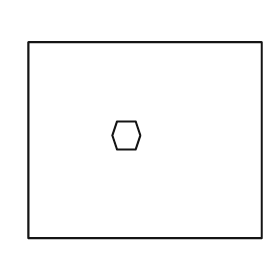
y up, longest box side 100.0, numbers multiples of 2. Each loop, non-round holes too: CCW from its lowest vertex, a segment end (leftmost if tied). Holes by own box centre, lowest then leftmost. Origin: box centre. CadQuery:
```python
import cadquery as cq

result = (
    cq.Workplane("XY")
    .moveTo(-50.0, -42.0)
    .lineTo(50.0, -42.0)
    .lineTo(50.0, 42.0)
    .lineTo(-50.0, 42.0)
    .close()
    .moveTo(-12.0, -4.0)
    .lineTo(-4.0, -4.0)
    .lineTo(-2.0, 2.0)
    .lineTo(-4.0, 8.0)
    .lineTo(-12.0, 8.0)
    .lineTo(-14.0, 2.0)
    .close()
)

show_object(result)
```